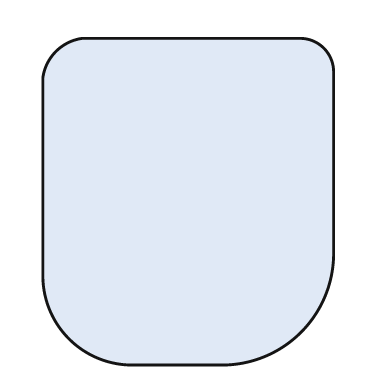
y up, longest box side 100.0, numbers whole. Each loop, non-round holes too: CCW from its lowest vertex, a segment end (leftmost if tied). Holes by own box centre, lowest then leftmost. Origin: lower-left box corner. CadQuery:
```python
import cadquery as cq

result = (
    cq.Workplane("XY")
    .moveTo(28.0, 0.0)
    .lineTo(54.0, 0.0)
    .threePointArc((79.0, 10.0), (89.0, 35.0))
    .lineTo(89.0, 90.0)
    .threePointArc((86.0, 97.0), (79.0, 100.0))
    .lineTo(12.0, 100.0)
    .threePointArc((4.0, 96.0), (0.0, 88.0))
    .lineTo(0.0, 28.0)
    .threePointArc((8.0, 8.0), (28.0, 0.0))
    .close()
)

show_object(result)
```